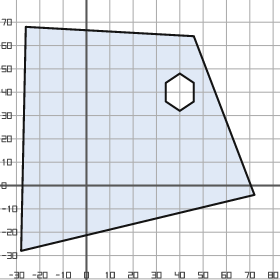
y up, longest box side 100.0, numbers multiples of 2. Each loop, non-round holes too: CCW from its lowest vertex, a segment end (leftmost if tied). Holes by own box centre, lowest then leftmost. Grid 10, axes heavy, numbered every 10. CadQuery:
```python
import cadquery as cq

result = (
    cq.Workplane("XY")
    .moveTo(-28.0, -28.0)
    .lineTo(72.0, -4.0)
    .lineTo(46.0, 64.0)
    .lineTo(-26.0, 68.0)
    .close()
    .moveTo(40.0, 32.0)
    .lineTo(46.0, 36.0)
    .lineTo(46.0, 44.0)
    .lineTo(40.0, 48.0)
    .lineTo(34.0, 44.0)
    .lineTo(34.0, 36.0)
    .close()
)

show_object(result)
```